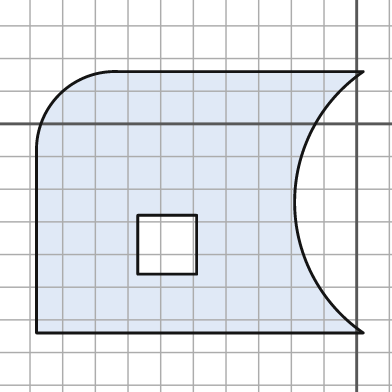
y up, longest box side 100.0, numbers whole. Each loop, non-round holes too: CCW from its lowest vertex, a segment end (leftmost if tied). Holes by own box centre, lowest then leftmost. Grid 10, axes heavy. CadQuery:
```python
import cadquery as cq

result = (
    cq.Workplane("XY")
    .moveTo(-98.0, -64.0)
    .lineTo(2.0, -64.0)
    .threePointArc((-19.0, -24.0), (2.0, 16.0))
    .lineTo(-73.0, 16.0)
    .threePointArc((-91.0, 9.0), (-98.0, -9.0))
    .close()
    .moveTo(-67.0, -46.0)
    .lineTo(-49.0, -46.0)
    .lineTo(-49.0, -28.0)
    .lineTo(-67.0, -28.0)
    .close()
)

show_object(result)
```